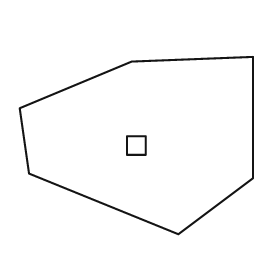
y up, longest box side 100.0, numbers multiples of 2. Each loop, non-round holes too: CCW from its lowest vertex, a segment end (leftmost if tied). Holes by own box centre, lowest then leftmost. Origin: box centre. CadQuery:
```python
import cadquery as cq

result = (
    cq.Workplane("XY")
    .moveTo(18.0, -38.0)
    .lineTo(50.0, -14.0)
    .lineTo(50.0, 38.0)
    .lineTo(-2.0, 36.0)
    .lineTo(-50.0, 16.0)
    .lineTo(-46.0, -12.0)
    .close()
    .moveTo(-4.0, -4.0)
    .lineTo(4.0, -4.0)
    .lineTo(4.0, 4.0)
    .lineTo(-4.0, 4.0)
    .close()
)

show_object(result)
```